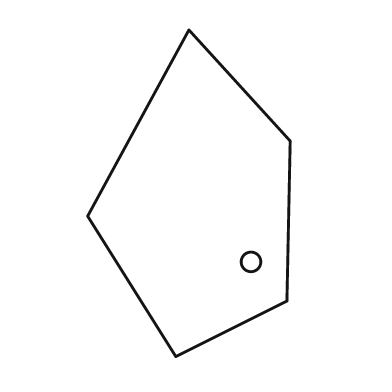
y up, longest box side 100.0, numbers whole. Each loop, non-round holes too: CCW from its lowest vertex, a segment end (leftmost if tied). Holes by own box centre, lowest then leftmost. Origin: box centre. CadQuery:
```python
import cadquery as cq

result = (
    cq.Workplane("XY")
    .moveTo(-4.0, -50.0)
    .lineTo(30.0, -33.0)
    .lineTo(31.0, 16.0)
    .lineTo(0.0, 50.0)
    .lineTo(-31.0, -7.0)
    .close()
    .moveTo(19.0, -21.0)
    .circle(3.0)
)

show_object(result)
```